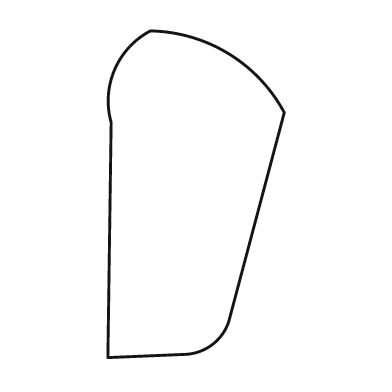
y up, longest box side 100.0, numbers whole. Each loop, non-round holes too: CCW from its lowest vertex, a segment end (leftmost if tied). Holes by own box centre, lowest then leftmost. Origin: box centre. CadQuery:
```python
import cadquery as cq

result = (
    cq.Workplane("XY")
    .moveTo(-27.0, -50.0)
    .lineTo(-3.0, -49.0)
    .threePointArc((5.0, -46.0), (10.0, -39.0))
    .lineTo(27.0, 25.0)
    .threePointArc((10.0, 43.0), (-14.0, 50.0))
    .threePointArc((-25.0, 38.0), (-26.0, 22.0))
    .close()
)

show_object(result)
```